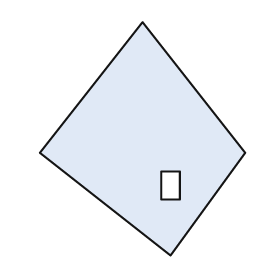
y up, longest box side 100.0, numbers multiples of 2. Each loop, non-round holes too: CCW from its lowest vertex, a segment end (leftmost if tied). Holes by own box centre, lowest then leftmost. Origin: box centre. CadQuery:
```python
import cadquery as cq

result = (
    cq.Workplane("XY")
    .moveTo(12.0, -50.0)
    .lineTo(44.0, -6.0)
    .lineTo(0.0, 50.0)
    .lineTo(-44.0, -6.0)
    .close()
    .moveTo(8.0, -26.0)
    .lineTo(16.0, -26.0)
    .lineTo(16.0, -14.0)
    .lineTo(8.0, -14.0)
    .close()
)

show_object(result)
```